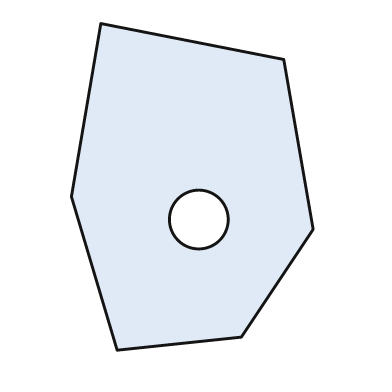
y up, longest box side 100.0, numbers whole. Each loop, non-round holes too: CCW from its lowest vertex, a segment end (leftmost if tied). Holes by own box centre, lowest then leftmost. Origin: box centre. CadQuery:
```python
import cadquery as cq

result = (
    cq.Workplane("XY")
    .moveTo(-23.0, -50.0)
    .lineTo(15.0, -46.0)
    .lineTo(37.0, -13.0)
    .lineTo(28.0, 39.0)
    .lineTo(-28.0, 50.0)
    .lineTo(-37.0, -3.0)
    .close()
    .moveTo(2.0, -10.0)
    .circle(9.0)
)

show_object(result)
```